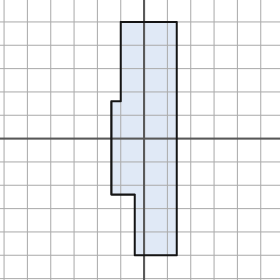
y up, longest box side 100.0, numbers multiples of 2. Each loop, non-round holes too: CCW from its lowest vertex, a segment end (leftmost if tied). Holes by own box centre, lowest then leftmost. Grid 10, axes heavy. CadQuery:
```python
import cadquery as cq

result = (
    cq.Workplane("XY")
    .moveTo(-4.0, -50.0)
    .lineTo(14.0, -50.0)
    .lineTo(14.0, 50.0)
    .lineTo(-10.0, 50.0)
    .lineTo(-10.0, 16.0)
    .lineTo(-14.0, 16.0)
    .lineTo(-14.0, -24.0)
    .lineTo(-4.0, -24.0)
    .close()
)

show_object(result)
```